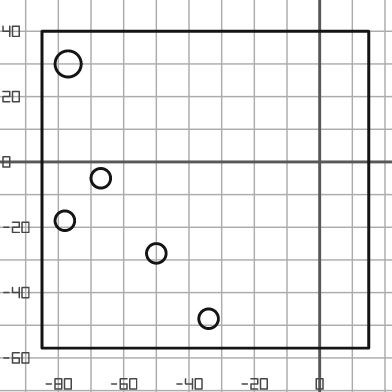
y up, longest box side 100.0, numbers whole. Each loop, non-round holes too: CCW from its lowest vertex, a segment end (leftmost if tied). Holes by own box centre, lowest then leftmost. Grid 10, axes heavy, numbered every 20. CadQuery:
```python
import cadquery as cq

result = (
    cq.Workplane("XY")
    .moveTo(-85.0, -57.0)
    .lineTo(15.0, -57.0)
    .lineTo(15.0, 40.0)
    .lineTo(-85.0, 40.0)
    .close()
    .moveTo(-34.0, -48.0)
    .circle(3.0)
    .moveTo(-50.0, -28.0)
    .circle(3.0)
    .moveTo(-78.0, -18.0)
    .circle(3.0)
    .moveTo(-67.0, -5.0)
    .circle(3.0)
    .moveTo(-77.0, 30.0)
    .circle(4.0)
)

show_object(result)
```